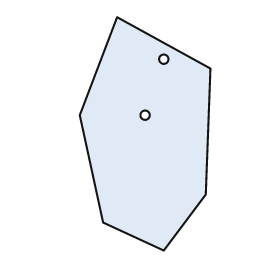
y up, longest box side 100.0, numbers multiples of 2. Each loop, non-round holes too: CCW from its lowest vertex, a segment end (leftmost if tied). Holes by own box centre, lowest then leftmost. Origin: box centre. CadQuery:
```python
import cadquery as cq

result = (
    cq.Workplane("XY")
    .moveTo(8.0, -50.0)
    .lineTo(26.0, -26.0)
    .lineTo(28.0, 28.0)
    .lineTo(-12.0, 50.0)
    .lineTo(-28.0, 8.0)
    .lineTo(-18.0, -38.0)
    .close()
    .moveTo(0.0, 8.0)
    .circle(2.0)
    .moveTo(8.0, 32.0)
    .circle(2.0)
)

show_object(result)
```